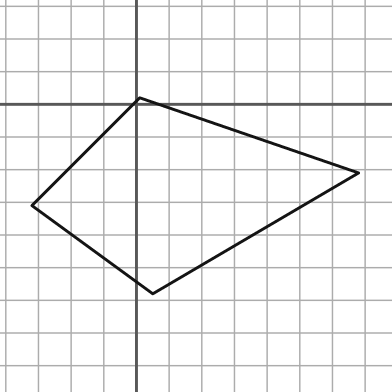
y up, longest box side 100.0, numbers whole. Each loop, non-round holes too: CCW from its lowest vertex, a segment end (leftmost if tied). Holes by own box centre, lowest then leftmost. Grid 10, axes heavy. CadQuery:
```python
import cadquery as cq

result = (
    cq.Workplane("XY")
    .moveTo(5.0, -58.0)
    .lineTo(68.0, -21.0)
    .lineTo(1.0, 2.0)
    .lineTo(-32.0, -31.0)
    .close()
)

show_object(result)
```